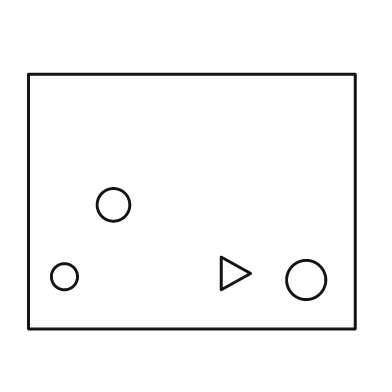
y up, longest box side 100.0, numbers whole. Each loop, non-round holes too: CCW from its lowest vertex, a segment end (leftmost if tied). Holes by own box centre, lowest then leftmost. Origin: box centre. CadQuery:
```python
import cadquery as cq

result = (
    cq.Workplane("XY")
    .moveTo(-50.0, -39.0)
    .lineTo(50.0, -39.0)
    .lineTo(50.0, 39.0)
    .lineTo(-50.0, 39.0)
    .close()
    .moveTo(35.0, -24.0)
    .circle(6.0)
    .moveTo(-39.0, -23.0)
    .circle(4.0)
    .moveTo(9.0, -27.0)
    .lineTo(18.0, -22.0)
    .lineTo(9.0, -17.0)
    .close()
    .moveTo(-24.0, -1.0)
    .circle(5.0)
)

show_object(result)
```